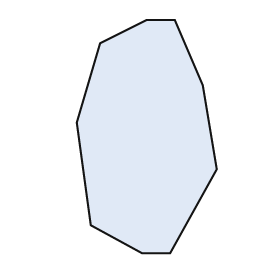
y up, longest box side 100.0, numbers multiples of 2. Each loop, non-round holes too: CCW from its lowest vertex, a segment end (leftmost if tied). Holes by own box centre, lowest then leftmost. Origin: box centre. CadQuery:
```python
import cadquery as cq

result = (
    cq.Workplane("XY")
    .moveTo(-2.0, -50.0)
    .lineTo(10.0, -50.0)
    .lineTo(30.0, -14.0)
    .lineTo(24.0, 22.0)
    .lineTo(12.0, 50.0)
    .lineTo(0.0, 50.0)
    .lineTo(-20.0, 40.0)
    .lineTo(-30.0, 6.0)
    .lineTo(-24.0, -38.0)
    .close()
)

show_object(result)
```